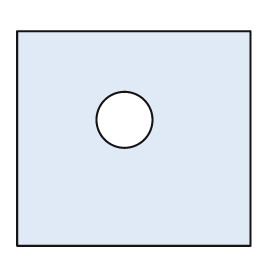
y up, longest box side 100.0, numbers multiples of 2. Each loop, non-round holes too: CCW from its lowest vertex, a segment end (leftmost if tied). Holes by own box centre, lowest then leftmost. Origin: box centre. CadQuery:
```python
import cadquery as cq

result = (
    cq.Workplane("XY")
    .moveTo(-50.0, -46.0)
    .lineTo(50.0, -46.0)
    .lineTo(50.0, 46.0)
    .lineTo(-50.0, 46.0)
    .close()
    .moveTo(-4.0, 8.0)
    .circle(12.0)
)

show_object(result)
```